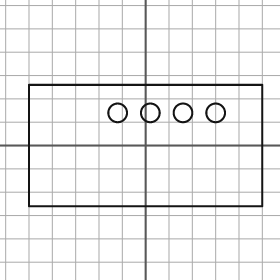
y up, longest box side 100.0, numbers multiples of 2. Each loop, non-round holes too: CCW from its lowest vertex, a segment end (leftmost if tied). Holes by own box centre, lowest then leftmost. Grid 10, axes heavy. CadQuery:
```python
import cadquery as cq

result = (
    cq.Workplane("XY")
    .moveTo(-50.0, -26.0)
    .lineTo(50.0, -26.0)
    .lineTo(50.0, 26.0)
    .lineTo(-50.0, 26.0)
    .close()
    .moveTo(-12.0, 14.0)
    .circle(4.0)
    .moveTo(2.0, 14.0)
    .circle(4.0)
    .moveTo(16.0, 14.0)
    .circle(4.0)
    .moveTo(30.0, 14.0)
    .circle(4.0)
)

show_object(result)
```